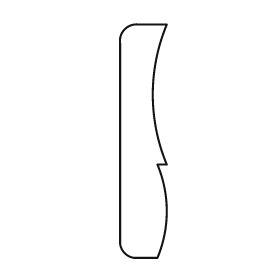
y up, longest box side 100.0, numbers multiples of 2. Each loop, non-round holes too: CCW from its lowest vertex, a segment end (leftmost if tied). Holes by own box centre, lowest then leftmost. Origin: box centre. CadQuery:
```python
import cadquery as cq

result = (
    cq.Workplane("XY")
    .moveTo(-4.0, -50.0)
    .lineTo(6.0, -50.0)
    .threePointArc((10.0, -30.0), (6.0, -10.0))
    .lineTo(10.0, -10.0)
    .threePointArc((4.0, 20.0), (10.0, 50.0))
    .lineTo(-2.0, 50.0)
    .threePointArc((-8.0, 48.0), (-10.0, 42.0))
    .lineTo(-10.0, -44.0)
    .threePointArc((-8.0, -48.0), (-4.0, -50.0))
    .close()
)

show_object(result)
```